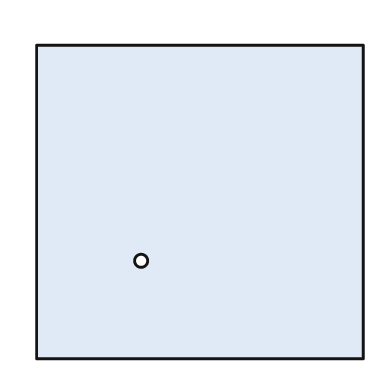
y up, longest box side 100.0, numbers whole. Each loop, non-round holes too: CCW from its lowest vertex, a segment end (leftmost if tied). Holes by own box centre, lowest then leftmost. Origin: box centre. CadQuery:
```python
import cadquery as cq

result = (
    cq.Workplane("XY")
    .moveTo(-50.0, -48.0)
    .lineTo(50.0, -48.0)
    .lineTo(50.0, 48.0)
    .lineTo(-50.0, 48.0)
    .close()
    .moveTo(-18.0, -18.0)
    .circle(2.0)
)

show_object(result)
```